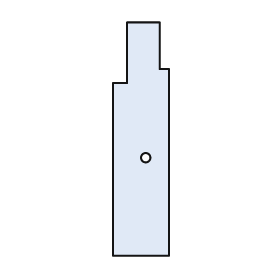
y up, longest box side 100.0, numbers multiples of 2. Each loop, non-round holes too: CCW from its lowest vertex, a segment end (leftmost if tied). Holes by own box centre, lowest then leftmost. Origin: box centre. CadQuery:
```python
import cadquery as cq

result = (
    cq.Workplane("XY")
    .moveTo(-12.0, -50.0)
    .lineTo(12.0, -50.0)
    .lineTo(12.0, 30.0)
    .lineTo(8.0, 30.0)
    .lineTo(8.0, 50.0)
    .lineTo(-6.0, 50.0)
    .lineTo(-6.0, 24.0)
    .lineTo(-12.0, 24.0)
    .close()
    .moveTo(2.0, -8.0)
    .circle(2.0)
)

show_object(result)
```